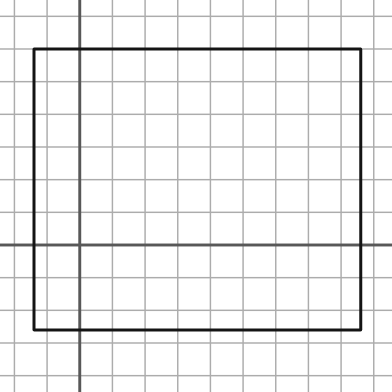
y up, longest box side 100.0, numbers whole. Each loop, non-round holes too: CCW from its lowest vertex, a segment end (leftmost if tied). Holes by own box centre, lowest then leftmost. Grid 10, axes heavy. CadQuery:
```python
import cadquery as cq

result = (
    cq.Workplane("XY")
    .moveTo(-14.0, -26.0)
    .lineTo(86.0, -26.0)
    .lineTo(86.0, 60.0)
    .lineTo(-14.0, 60.0)
    .close()
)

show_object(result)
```